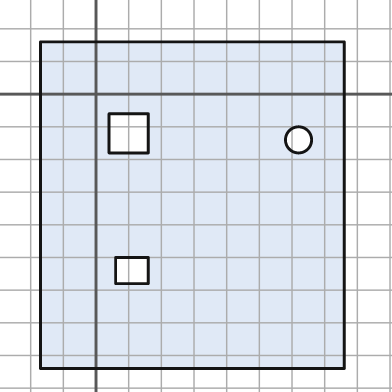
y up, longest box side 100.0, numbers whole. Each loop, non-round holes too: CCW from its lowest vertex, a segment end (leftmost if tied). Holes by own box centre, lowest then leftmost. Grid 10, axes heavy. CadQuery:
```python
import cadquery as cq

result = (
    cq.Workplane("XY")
    .moveTo(-17.0, -84.0)
    .lineTo(76.0, -84.0)
    .lineTo(76.0, 16.0)
    .lineTo(-17.0, 16.0)
    .close()
    .moveTo(6.0, -58.0)
    .lineTo(16.0, -58.0)
    .lineTo(16.0, -50.0)
    .lineTo(6.0, -50.0)
    .close()
    .moveTo(62.0, -14.0)
    .circle(4.0)
    .moveTo(4.0, -18.0)
    .lineTo(16.0, -18.0)
    .lineTo(16.0, -6.0)
    .lineTo(4.0, -6.0)
    .close()
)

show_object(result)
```